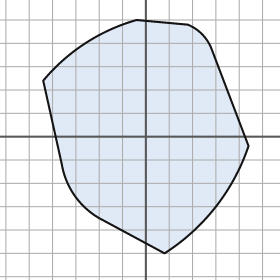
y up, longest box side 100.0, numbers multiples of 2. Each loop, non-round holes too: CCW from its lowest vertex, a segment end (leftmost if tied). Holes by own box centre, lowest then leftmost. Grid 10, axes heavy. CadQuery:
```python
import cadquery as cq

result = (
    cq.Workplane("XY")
    .moveTo(8.0, -50.0)
    .threePointArc((30.0, -30.0), (44.0, -4.0))
    .lineTo(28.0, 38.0)
    .threePointArc((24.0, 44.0), (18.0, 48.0))
    .lineTo(-4.0, 50.0)
    .threePointArc((-26.0, 40.0), (-44.0, 24.0))
    .lineTo(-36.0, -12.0)
    .threePointArc((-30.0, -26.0), (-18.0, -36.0))
    .close()
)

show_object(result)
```